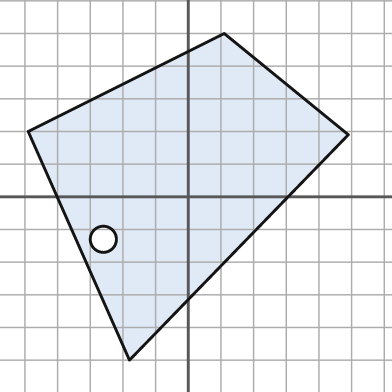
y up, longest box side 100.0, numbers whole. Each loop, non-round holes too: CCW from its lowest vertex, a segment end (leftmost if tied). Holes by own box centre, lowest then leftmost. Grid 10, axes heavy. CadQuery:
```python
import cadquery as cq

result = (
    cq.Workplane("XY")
    .moveTo(-18.0, -50.0)
    .lineTo(49.0, 19.0)
    .lineTo(11.0, 50.0)
    .lineTo(-49.0, 20.0)
    .close()
    .moveTo(-26.0, -13.0)
    .circle(4.0)
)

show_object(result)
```